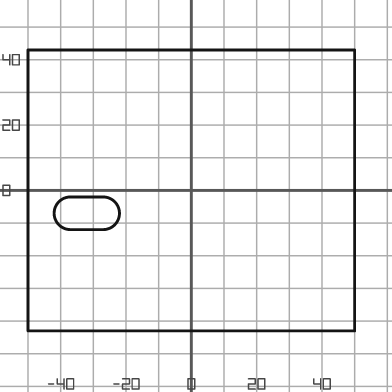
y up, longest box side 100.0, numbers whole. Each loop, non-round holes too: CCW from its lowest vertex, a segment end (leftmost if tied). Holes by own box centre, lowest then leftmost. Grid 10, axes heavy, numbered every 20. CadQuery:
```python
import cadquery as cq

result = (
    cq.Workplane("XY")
    .moveTo(-50.0, -43.0)
    .lineTo(50.0, -43.0)
    .lineTo(50.0, 43.0)
    .lineTo(-50.0, 43.0)
    .close()
    .moveTo(-37.0, -12.0)
    .lineTo(-27.0, -12.0)
    .threePointArc((-22.0, -7.0), (-27.0, -2.0))
    .lineTo(-37.0, -2.0)
    .threePointArc((-42.0, -7.0), (-37.0, -12.0))
    .close()
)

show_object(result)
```